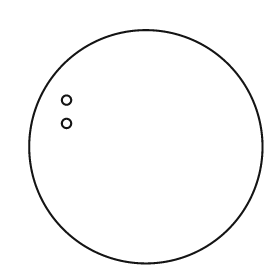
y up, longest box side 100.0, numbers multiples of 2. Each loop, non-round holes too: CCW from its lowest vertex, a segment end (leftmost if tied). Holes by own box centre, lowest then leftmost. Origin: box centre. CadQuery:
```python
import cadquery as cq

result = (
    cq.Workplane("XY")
    .moveTo(0.0, 0.0)
    .circle(50.0)
    .moveTo(-34.0, 10.0)
    .circle(2.0)
    .moveTo(-34.0, 20.0)
    .circle(2.0)
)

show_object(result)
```